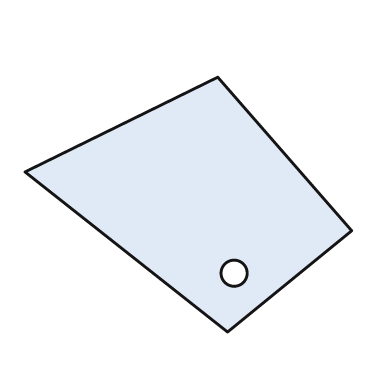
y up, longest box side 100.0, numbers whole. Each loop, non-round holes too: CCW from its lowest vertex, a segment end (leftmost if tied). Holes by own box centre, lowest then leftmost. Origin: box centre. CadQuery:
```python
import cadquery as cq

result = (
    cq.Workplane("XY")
    .moveTo(12.0, -39.0)
    .lineTo(50.0, -8.0)
    .lineTo(9.0, 39.0)
    .lineTo(-50.0, 10.0)
    .close()
    .moveTo(14.0, -21.0)
    .circle(4.0)
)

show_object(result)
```